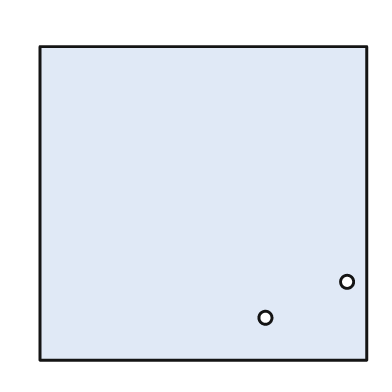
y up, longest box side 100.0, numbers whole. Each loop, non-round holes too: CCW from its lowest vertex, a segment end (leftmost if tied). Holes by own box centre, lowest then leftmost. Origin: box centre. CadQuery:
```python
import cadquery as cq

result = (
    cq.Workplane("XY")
    .moveTo(-50.0, -48.0)
    .lineTo(50.0, -48.0)
    .lineTo(50.0, 48.0)
    .lineTo(-50.0, 48.0)
    .close()
    .moveTo(19.0, -35.0)
    .circle(2.0)
    .moveTo(44.0, -24.0)
    .circle(2.0)
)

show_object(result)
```